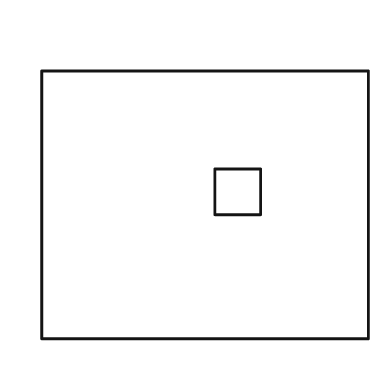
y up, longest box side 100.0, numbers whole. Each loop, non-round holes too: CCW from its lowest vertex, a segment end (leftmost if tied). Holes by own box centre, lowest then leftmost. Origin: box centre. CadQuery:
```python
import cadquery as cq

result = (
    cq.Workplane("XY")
    .moveTo(-50.0, -41.0)
    .lineTo(50.0, -41.0)
    .lineTo(50.0, 41.0)
    .lineTo(-50.0, 41.0)
    .close()
    .moveTo(3.0, -3.0)
    .lineTo(17.0, -3.0)
    .lineTo(17.0, 11.0)
    .lineTo(3.0, 11.0)
    .close()
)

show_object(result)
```